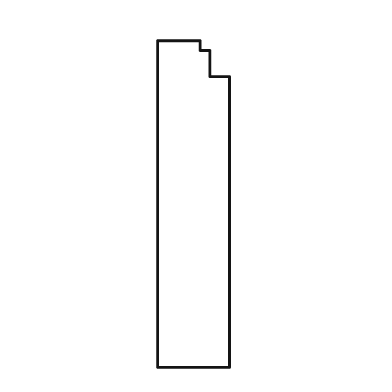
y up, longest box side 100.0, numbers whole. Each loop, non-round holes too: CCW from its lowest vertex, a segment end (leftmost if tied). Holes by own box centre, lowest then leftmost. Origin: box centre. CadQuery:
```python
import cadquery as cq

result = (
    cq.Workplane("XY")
    .moveTo(-11.0, -50.0)
    .lineTo(11.0, -50.0)
    .lineTo(11.0, 39.0)
    .lineTo(5.0, 39.0)
    .lineTo(5.0, 47.0)
    .lineTo(2.0, 47.0)
    .lineTo(2.0, 50.0)
    .lineTo(-11.0, 50.0)
    .close()
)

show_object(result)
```